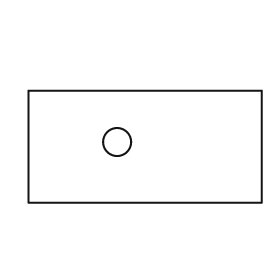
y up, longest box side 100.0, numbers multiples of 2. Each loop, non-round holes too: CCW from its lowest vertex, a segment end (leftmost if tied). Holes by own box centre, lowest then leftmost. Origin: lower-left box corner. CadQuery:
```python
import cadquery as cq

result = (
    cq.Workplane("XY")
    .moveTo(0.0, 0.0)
    .lineTo(100.0, 0.0)
    .lineTo(100.0, 48.0)
    .lineTo(0.0, 48.0)
    .close()
    .moveTo(38.0, 26.0)
    .circle(6.0)
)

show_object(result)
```